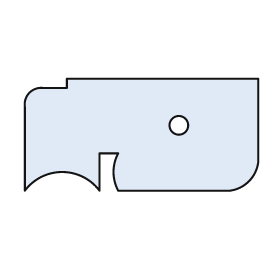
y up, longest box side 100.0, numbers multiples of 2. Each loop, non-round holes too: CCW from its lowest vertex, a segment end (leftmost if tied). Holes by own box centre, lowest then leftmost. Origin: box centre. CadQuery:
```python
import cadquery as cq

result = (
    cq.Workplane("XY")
    .moveTo(-50.0, -24.0)
    .threePointArc((-34.0, -16.0), (-18.0, -24.0))
    .lineTo(-18.0, -8.0)
    .lineTo(-10.0, -8.0)
    .threePointArc((-12.0, -16.0), (-10.0, -24.0))
    .lineTo(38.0, -24.0)
    .threePointArc((46.0, -20.0), (50.0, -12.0))
    .lineTo(50.0, 24.0)
    .lineTo(-32.0, 24.0)
    .lineTo(-32.0, 20.0)
    .lineTo(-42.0, 20.0)
    .threePointArc((-48.0, 18.0), (-50.0, 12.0))
    .close()
    .moveTo(16.0, 4.0)
    .circle(4.0)
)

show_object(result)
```